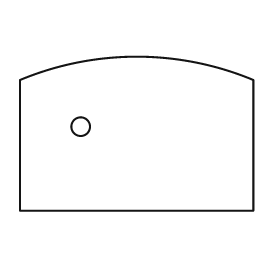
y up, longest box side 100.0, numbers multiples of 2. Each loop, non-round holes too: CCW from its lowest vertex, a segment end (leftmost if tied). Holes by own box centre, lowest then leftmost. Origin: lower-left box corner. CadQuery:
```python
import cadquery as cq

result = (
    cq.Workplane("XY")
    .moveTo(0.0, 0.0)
    .lineTo(100.0, 0.0)
    .lineTo(100.0, 56.0)
    .threePointArc((50.0, 66.0), (0.0, 56.0))
    .close()
    .moveTo(26.0, 36.0)
    .circle(4.0)
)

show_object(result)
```